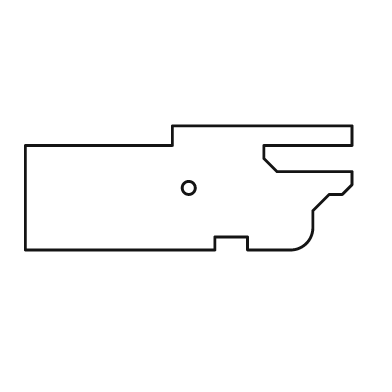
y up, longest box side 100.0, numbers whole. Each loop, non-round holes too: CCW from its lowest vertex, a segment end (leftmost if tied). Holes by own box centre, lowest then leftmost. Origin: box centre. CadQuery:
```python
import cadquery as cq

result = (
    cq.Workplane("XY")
    .moveTo(-50.0, -19.0)
    .lineTo(8.0, -19.0)
    .lineTo(8.0, -15.0)
    .lineTo(18.0, -15.0)
    .lineTo(18.0, -19.0)
    .lineTo(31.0, -19.0)
    .threePointArc((36.0, -17.0), (38.0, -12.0))
    .lineTo(38.0, -7.0)
    .lineTo(43.0, -2.0)
    .lineTo(47.0, -2.0)
    .lineTo(50.0, 1.0)
    .lineTo(50.0, 5.0)
    .lineTo(27.0, 5.0)
    .lineTo(23.0, 9.0)
    .lineTo(23.0, 13.0)
    .lineTo(50.0, 13.0)
    .lineTo(50.0, 19.0)
    .lineTo(-5.0, 19.0)
    .lineTo(-5.0, 13.0)
    .lineTo(-50.0, 13.0)
    .close()
    .moveTo(0.0, 0.0)
    .circle(2.0)
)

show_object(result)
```